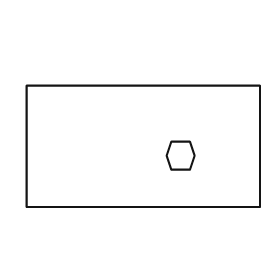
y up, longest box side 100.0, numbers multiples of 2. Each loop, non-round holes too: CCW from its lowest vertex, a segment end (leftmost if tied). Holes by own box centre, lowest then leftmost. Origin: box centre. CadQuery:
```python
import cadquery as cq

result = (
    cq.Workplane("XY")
    .moveTo(-50.0, -26.0)
    .lineTo(50.0, -26.0)
    .lineTo(50.0, 26.0)
    .lineTo(-50.0, 26.0)
    .close()
    .moveTo(12.0, -10.0)
    .lineTo(20.0, -10.0)
    .lineTo(22.0, -4.0)
    .lineTo(20.0, 2.0)
    .lineTo(12.0, 2.0)
    .lineTo(10.0, -4.0)
    .close()
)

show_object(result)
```